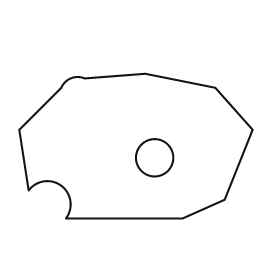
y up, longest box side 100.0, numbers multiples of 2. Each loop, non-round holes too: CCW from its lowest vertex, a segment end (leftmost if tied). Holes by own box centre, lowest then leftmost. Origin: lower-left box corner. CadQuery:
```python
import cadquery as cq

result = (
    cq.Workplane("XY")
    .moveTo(20.0, 0.0)
    .lineTo(70.0, 0.0)
    .lineTo(88.0, 8.0)
    .lineTo(100.0, 38.0)
    .lineTo(84.0, 56.0)
    .lineTo(54.0, 62.0)
    .lineTo(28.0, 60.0)
    .threePointArc((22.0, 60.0), (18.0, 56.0))
    .lineTo(0.0, 38.0)
    .lineTo(4.0, 12.0)
    .threePointArc((18.0, 14.0), (20.0, 0.0))
    .close()
    .moveTo(58.0, 26.0)
    .circle(8.0)
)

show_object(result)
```